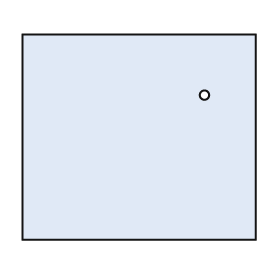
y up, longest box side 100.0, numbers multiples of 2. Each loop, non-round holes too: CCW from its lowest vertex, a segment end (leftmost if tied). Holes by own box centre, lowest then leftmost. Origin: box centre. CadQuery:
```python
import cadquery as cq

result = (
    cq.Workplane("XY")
    .moveTo(-50.0, -44.0)
    .lineTo(50.0, -44.0)
    .lineTo(50.0, 44.0)
    .lineTo(-50.0, 44.0)
    .close()
    .moveTo(28.0, 18.0)
    .circle(2.0)
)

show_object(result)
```